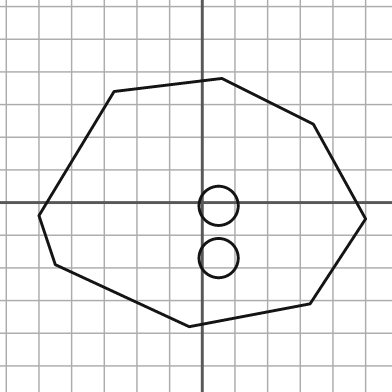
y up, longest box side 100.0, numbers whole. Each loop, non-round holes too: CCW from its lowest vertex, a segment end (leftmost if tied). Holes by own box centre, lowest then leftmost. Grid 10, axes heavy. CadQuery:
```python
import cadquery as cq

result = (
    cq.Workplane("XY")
    .moveTo(-4.0, -38.0)
    .lineTo(33.0, -31.0)
    .lineTo(50.0, -5.0)
    .lineTo(34.0, 24.0)
    .lineTo(6.0, 38.0)
    .lineTo(-27.0, 34.0)
    .lineTo(-50.0, -4.0)
    .lineTo(-45.0, -19.0)
    .close()
    .moveTo(5.0, -17.0)
    .circle(6.0)
    .moveTo(5.0, -1.0)
    .circle(6.0)
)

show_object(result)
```